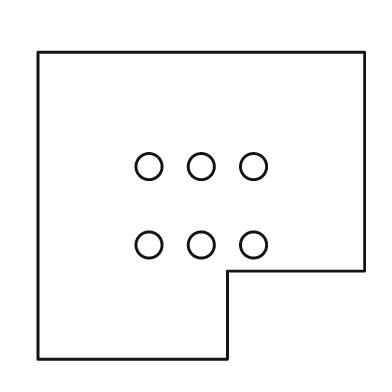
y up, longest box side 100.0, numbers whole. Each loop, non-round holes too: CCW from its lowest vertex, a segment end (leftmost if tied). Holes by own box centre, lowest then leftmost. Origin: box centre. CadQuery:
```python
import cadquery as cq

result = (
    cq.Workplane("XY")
    .moveTo(-50.0, -47.0)
    .lineTo(8.0, -47.0)
    .lineTo(8.0, -20.0)
    .lineTo(50.0, -20.0)
    .lineTo(50.0, 47.0)
    .lineTo(-50.0, 47.0)
    .close()
    .moveTo(-16.0, -12.0)
    .circle(4.0)
    .moveTo(0.0, -12.0)
    .circle(4.0)
    .moveTo(16.0, -12.0)
    .circle(4.0)
    .moveTo(-16.0, 12.0)
    .circle(4.0)
    .moveTo(0.0, 12.0)
    .circle(4.0)
    .moveTo(16.0, 12.0)
    .circle(4.0)
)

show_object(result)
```